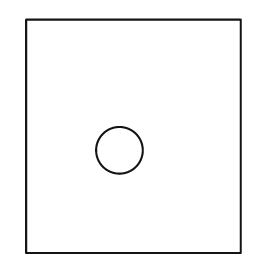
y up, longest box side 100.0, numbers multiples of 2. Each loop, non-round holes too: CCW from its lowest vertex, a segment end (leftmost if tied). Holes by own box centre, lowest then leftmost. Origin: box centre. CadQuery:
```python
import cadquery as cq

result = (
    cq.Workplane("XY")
    .moveTo(-46.0, -50.0)
    .lineTo(46.0, -50.0)
    .lineTo(46.0, 50.0)
    .lineTo(-46.0, 50.0)
    .close()
    .moveTo(-6.0, -6.0)
    .circle(10.0)
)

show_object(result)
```